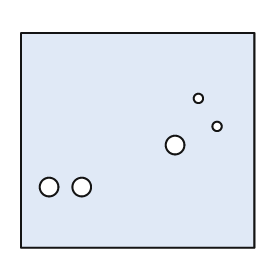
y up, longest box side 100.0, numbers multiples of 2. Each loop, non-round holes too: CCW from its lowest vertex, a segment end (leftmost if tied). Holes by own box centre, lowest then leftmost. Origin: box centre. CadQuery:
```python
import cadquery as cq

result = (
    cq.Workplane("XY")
    .moveTo(-50.0, -46.0)
    .lineTo(50.0, -46.0)
    .lineTo(50.0, 46.0)
    .lineTo(-50.0, 46.0)
    .close()
    .moveTo(-38.0, -20.0)
    .circle(4.0)
    .moveTo(-24.0, -20.0)
    .circle(4.0)
    .moveTo(16.0, -2.0)
    .circle(4.0)
    .moveTo(34.0, 6.0)
    .circle(2.0)
    .moveTo(26.0, 18.0)
    .circle(2.0)
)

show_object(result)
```